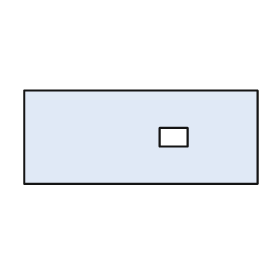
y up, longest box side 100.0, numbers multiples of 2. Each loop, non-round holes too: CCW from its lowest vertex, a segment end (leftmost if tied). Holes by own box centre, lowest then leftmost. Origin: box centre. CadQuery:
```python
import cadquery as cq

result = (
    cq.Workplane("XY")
    .moveTo(-50.0, -20.0)
    .lineTo(50.0, -20.0)
    .lineTo(50.0, 20.0)
    .lineTo(-50.0, 20.0)
    .close()
    .moveTo(8.0, -4.0)
    .lineTo(20.0, -4.0)
    .lineTo(20.0, 4.0)
    .lineTo(8.0, 4.0)
    .close()
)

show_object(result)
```